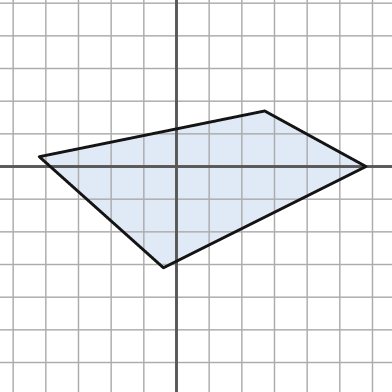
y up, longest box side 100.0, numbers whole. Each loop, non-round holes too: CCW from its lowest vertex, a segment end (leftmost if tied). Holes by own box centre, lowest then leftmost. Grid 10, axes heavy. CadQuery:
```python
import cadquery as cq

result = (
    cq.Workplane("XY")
    .moveTo(-4.0, -31.0)
    .lineTo(58.0, 0.0)
    .lineTo(27.0, 17.0)
    .lineTo(-42.0, 3.0)
    .close()
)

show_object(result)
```